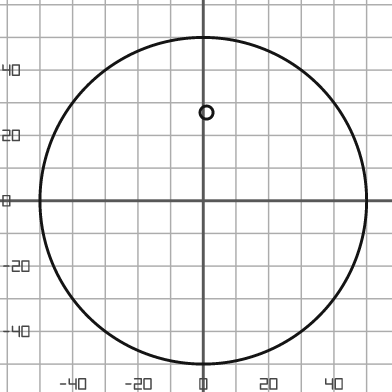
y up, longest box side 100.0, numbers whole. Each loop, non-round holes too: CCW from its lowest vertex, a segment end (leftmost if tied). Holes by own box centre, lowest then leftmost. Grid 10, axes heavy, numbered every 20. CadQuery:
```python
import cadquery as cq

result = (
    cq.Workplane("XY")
    .moveTo(0.0, 0.0)
    .circle(50.0)
    .moveTo(1.0, 27.0)
    .circle(2.0)
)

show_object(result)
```